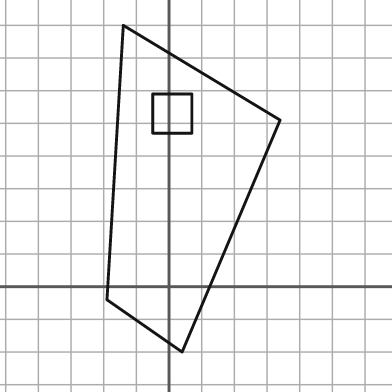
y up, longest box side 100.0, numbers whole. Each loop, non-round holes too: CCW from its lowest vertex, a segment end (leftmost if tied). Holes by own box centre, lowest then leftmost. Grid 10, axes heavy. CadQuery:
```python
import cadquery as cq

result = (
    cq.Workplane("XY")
    .moveTo(4.0, -20.0)
    .lineTo(34.0, 51.0)
    .lineTo(-14.0, 80.0)
    .lineTo(-19.0, -4.0)
    .close()
    .moveTo(-5.0, 47.0)
    .lineTo(7.0, 47.0)
    .lineTo(7.0, 59.0)
    .lineTo(-5.0, 59.0)
    .close()
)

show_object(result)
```